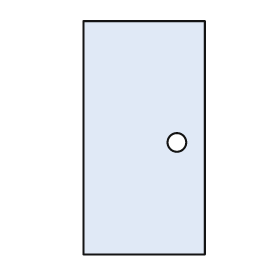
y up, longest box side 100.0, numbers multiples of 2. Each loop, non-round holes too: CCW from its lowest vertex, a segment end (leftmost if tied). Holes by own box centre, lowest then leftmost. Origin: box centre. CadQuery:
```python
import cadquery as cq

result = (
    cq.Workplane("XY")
    .moveTo(-26.0, -50.0)
    .lineTo(26.0, -50.0)
    .lineTo(26.0, 50.0)
    .lineTo(-26.0, 50.0)
    .close()
    .moveTo(14.0, -2.0)
    .circle(4.0)
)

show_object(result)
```